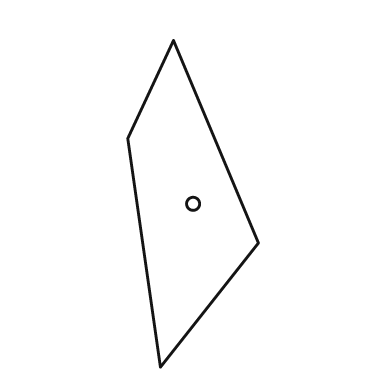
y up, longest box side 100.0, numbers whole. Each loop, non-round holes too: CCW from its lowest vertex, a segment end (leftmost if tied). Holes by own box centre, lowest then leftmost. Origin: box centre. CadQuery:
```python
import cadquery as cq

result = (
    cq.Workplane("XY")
    .moveTo(-10.0, -50.0)
    .lineTo(20.0, -12.0)
    .lineTo(-6.0, 50.0)
    .lineTo(-20.0, 20.0)
    .close()
    .moveTo(0.0, 0.0)
    .circle(2.0)
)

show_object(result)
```